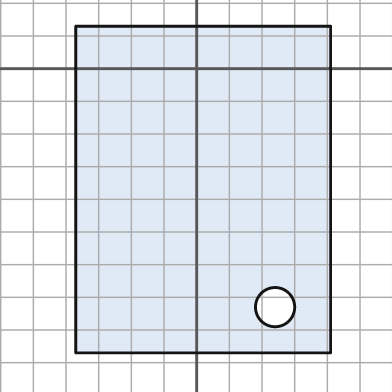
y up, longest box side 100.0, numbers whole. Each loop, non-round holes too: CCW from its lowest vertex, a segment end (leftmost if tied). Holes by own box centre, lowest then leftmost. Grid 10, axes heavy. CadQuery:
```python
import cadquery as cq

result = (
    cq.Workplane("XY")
    .moveTo(-37.0, -87.0)
    .lineTo(41.0, -87.0)
    .lineTo(41.0, 13.0)
    .lineTo(-37.0, 13.0)
    .close()
    .moveTo(24.0, -73.0)
    .circle(6.0)
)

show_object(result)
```